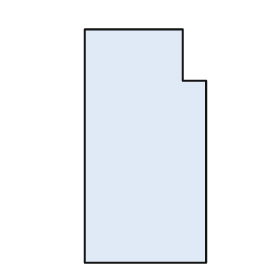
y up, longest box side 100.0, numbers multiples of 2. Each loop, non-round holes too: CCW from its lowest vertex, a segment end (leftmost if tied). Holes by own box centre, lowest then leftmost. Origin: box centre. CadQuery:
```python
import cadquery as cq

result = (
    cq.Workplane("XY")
    .moveTo(-26.0, -50.0)
    .lineTo(26.0, -50.0)
    .lineTo(26.0, 28.0)
    .lineTo(16.0, 28.0)
    .lineTo(16.0, 50.0)
    .lineTo(-26.0, 50.0)
    .close()
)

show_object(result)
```